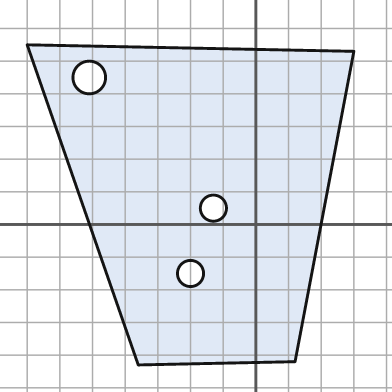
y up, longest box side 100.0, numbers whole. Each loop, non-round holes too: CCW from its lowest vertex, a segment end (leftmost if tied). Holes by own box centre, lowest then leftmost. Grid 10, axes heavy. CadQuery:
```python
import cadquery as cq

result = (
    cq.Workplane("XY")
    .moveTo(-36.0, -43.0)
    .lineTo(12.0, -42.0)
    .lineTo(30.0, 53.0)
    .lineTo(-70.0, 55.0)
    .close()
    .moveTo(-20.0, -15.0)
    .circle(4.0)
    .moveTo(-13.0, 5.0)
    .circle(4.0)
    .moveTo(-51.0, 45.0)
    .circle(5.0)
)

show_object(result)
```